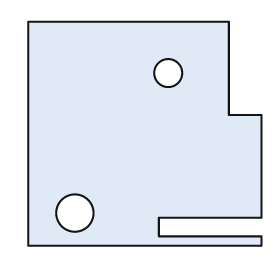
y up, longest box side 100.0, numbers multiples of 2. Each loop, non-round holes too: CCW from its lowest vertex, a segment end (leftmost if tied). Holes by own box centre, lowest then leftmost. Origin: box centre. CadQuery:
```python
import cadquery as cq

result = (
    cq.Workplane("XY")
    .moveTo(-50.0, -48.0)
    .lineTo(50.0, -48.0)
    .lineTo(50.0, -44.0)
    .lineTo(6.0, -44.0)
    .lineTo(6.0, -36.0)
    .lineTo(50.0, -36.0)
    .lineTo(50.0, 8.0)
    .lineTo(36.0, 8.0)
    .lineTo(36.0, 48.0)
    .lineTo(-50.0, 48.0)
    .close()
    .moveTo(-30.0, -34.0)
    .circle(8.0)
    .moveTo(10.0, 26.0)
    .circle(6.0)
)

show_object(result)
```